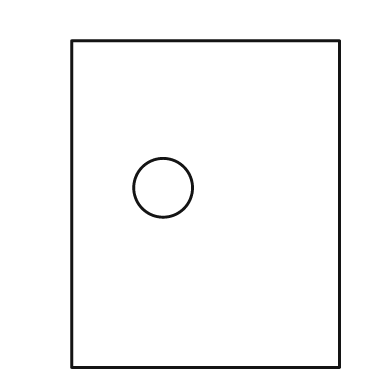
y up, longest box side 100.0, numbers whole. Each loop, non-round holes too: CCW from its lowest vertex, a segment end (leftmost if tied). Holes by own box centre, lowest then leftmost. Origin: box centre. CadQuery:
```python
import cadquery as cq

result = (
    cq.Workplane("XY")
    .moveTo(-41.0, -50.0)
    .lineTo(41.0, -50.0)
    .lineTo(41.0, 50.0)
    .lineTo(-41.0, 50.0)
    .close()
    .moveTo(-13.0, 5.0)
    .circle(9.0)
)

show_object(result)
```